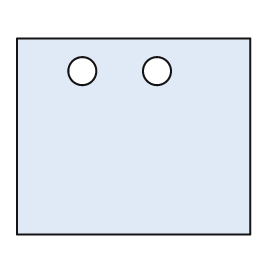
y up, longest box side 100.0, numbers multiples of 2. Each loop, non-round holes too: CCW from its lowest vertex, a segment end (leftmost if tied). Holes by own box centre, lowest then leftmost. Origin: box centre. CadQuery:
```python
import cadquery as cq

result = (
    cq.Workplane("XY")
    .moveTo(-50.0, -42.0)
    .lineTo(50.0, -42.0)
    .lineTo(50.0, 42.0)
    .lineTo(-50.0, 42.0)
    .close()
    .moveTo(-22.0, 28.0)
    .circle(6.0)
    .moveTo(10.0, 28.0)
    .circle(6.0)
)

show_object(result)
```